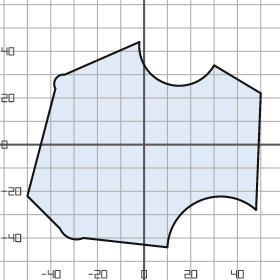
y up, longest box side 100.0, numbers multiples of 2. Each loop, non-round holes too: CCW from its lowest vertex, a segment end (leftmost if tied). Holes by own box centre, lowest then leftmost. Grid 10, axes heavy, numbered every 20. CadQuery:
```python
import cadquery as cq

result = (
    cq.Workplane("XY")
    .moveTo(10.0, -44.0)
    .threePointArc((24.0, -24.0), (48.0, -28.0))
    .lineTo(50.0, 22.0)
    .lineTo(30.0, 34.0)
    .threePointArc((10.0, 26.0), (-2.0, 44.0))
    .lineTo(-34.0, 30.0)
    .threePointArc((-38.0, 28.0), (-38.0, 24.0))
    .lineTo(-50.0, -22.0)
    .lineTo(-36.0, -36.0)
    .threePointArc((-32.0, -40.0), (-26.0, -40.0))
    .close()
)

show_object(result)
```